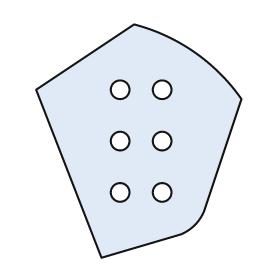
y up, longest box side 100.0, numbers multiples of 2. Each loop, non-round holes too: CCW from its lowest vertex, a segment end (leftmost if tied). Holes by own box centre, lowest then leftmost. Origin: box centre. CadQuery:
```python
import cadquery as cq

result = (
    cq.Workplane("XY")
    .moveTo(-16.0, -50.0)
    .lineTo(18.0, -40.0)
    .threePointArc((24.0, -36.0), (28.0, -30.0))
    .lineTo(44.0, 18.0)
    .threePointArc((24.0, 38.0), (-2.0, 50.0))
    .lineTo(-44.0, 22.0)
    .close()
    .moveTo(-8.0, -22.0)
    .circle(4.0)
    .moveTo(10.0, -22.0)
    .circle(4.0)
    .moveTo(-8.0, 0.0)
    .circle(4.0)
    .moveTo(10.0, 0.0)
    .circle(4.0)
    .moveTo(-8.0, 22.0)
    .circle(4.0)
    .moveTo(10.0, 22.0)
    .circle(4.0)
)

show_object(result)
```